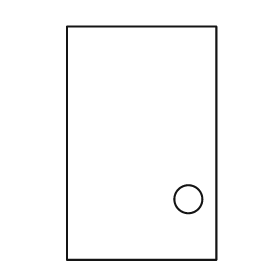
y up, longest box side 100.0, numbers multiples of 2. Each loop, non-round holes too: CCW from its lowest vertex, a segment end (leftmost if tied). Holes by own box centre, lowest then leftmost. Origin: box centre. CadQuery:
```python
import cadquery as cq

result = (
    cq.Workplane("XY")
    .moveTo(-32.0, -50.0)
    .lineTo(32.0, -50.0)
    .lineTo(32.0, 50.0)
    .lineTo(-32.0, 50.0)
    .close()
    .moveTo(20.0, -24.0)
    .circle(6.0)
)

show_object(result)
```